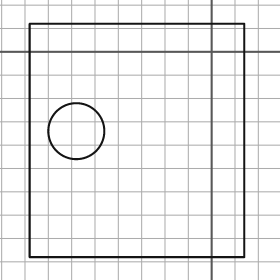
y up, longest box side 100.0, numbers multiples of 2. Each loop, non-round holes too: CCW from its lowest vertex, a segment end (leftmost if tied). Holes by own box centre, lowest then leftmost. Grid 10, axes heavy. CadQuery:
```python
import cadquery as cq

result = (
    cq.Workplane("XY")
    .moveTo(-78.0, -88.0)
    .lineTo(14.0, -88.0)
    .lineTo(14.0, 12.0)
    .lineTo(-78.0, 12.0)
    .close()
    .moveTo(-58.0, -34.0)
    .circle(12.0)
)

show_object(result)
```